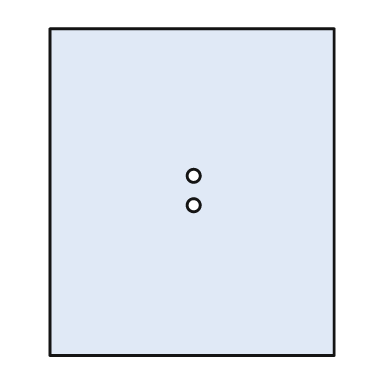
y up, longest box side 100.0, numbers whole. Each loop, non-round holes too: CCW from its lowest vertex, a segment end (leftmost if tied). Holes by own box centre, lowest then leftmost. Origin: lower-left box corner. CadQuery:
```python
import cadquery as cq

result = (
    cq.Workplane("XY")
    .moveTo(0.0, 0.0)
    .lineTo(87.0, 0.0)
    .lineTo(87.0, 100.0)
    .lineTo(0.0, 100.0)
    .close()
    .moveTo(44.0, 46.0)
    .circle(2.0)
    .moveTo(44.0, 55.0)
    .circle(2.0)
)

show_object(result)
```